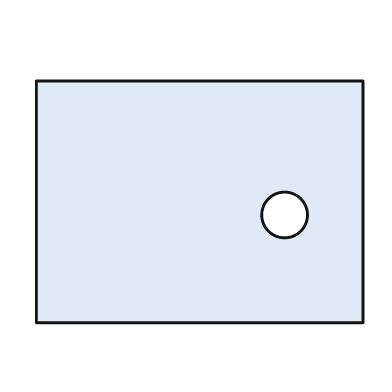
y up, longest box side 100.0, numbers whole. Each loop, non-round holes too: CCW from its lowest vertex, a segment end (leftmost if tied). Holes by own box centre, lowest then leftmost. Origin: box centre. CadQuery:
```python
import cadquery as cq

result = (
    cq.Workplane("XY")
    .moveTo(-50.0, -37.0)
    .lineTo(50.0, -37.0)
    .lineTo(50.0, 37.0)
    .lineTo(-50.0, 37.0)
    .close()
    .moveTo(26.0, -4.0)
    .circle(7.0)
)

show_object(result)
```